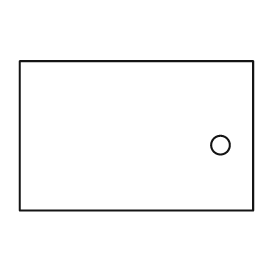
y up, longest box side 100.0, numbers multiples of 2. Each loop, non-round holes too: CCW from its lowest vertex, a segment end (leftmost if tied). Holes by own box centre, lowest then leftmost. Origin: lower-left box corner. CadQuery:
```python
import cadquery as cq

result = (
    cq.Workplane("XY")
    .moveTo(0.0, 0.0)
    .lineTo(100.0, 0.0)
    .lineTo(100.0, 64.0)
    .lineTo(0.0, 64.0)
    .close()
    .moveTo(86.0, 28.0)
    .circle(4.0)
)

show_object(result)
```